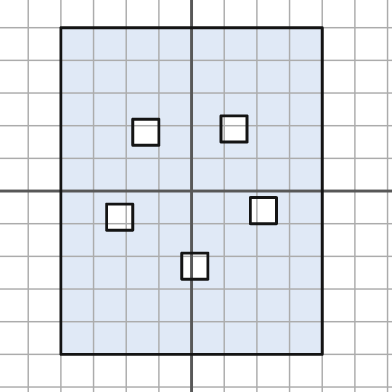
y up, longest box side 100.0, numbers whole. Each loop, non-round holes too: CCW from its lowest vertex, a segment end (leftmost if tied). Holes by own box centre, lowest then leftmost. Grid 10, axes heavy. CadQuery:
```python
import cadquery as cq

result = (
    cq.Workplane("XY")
    .moveTo(-40.0, -50.0)
    .lineTo(40.0, -50.0)
    .lineTo(40.0, 50.0)
    .lineTo(-40.0, 50.0)
    .close()
    .moveTo(-3.0, -27.0)
    .lineTo(5.0, -27.0)
    .lineTo(5.0, -19.0)
    .lineTo(-3.0, -19.0)
    .close()
    .moveTo(-26.0, -12.0)
    .lineTo(-18.0, -12.0)
    .lineTo(-18.0, -4.0)
    .lineTo(-26.0, -4.0)
    .close()
    .moveTo(18.0, -10.0)
    .lineTo(26.0, -10.0)
    .lineTo(26.0, -2.0)
    .lineTo(18.0, -2.0)
    .close()
    .moveTo(-18.0, 14.0)
    .lineTo(-10.0, 14.0)
    .lineTo(-10.0, 22.0)
    .lineTo(-18.0, 22.0)
    .close()
    .moveTo(9.0, 15.0)
    .lineTo(17.0, 15.0)
    .lineTo(17.0, 23.0)
    .lineTo(9.0, 23.0)
    .close()
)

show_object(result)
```